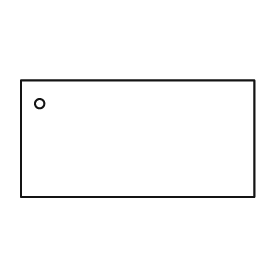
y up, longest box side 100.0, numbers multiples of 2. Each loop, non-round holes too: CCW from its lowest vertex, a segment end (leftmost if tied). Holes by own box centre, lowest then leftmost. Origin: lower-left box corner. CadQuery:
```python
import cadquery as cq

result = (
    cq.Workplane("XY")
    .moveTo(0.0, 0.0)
    .lineTo(100.0, 0.0)
    .lineTo(100.0, 50.0)
    .lineTo(0.0, 50.0)
    .close()
    .moveTo(8.0, 40.0)
    .circle(2.0)
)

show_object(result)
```